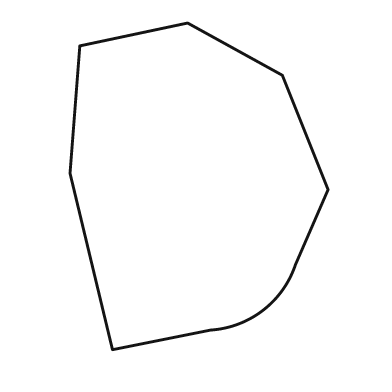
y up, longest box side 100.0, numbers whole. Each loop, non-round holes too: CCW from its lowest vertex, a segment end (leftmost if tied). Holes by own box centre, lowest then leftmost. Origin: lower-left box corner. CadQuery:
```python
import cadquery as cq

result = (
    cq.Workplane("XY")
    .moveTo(13.0, 0.0)
    .lineTo(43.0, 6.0)
    .threePointArc((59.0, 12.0), (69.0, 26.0))
    .lineTo(79.0, 49.0)
    .lineTo(65.0, 84.0)
    .lineTo(36.0, 100.0)
    .lineTo(3.0, 93.0)
    .lineTo(0.0, 54.0)
    .close()
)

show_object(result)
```